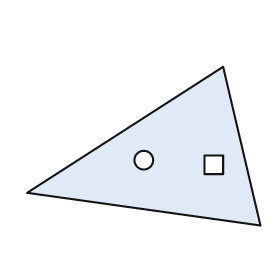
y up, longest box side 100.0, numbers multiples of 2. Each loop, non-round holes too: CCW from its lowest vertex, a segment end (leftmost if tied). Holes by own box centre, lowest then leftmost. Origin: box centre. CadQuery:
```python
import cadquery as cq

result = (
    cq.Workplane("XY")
    .moveTo(50.0, -34.0)
    .lineTo(34.0, 34.0)
    .lineTo(-50.0, -20.0)
    .close()
    .moveTo(26.0, -12.0)
    .lineTo(34.0, -12.0)
    .lineTo(34.0, -4.0)
    .lineTo(26.0, -4.0)
    .close()
    .moveTo(0.0, -6.0)
    .circle(4.0)
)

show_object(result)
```